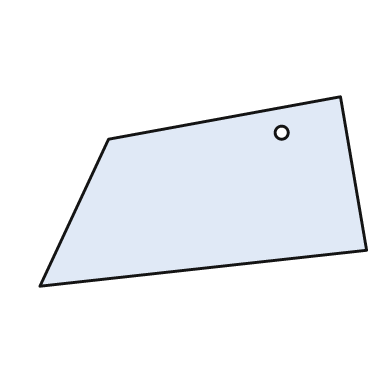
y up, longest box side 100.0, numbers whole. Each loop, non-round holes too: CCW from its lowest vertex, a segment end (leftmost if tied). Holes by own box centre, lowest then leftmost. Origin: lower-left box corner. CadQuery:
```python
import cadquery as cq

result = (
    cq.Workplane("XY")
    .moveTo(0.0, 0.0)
    .lineTo(100.0, 11.0)
    .lineTo(92.0, 58.0)
    .lineTo(21.0, 45.0)
    .close()
    .moveTo(74.0, 47.0)
    .circle(2.0)
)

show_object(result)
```